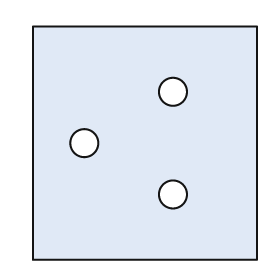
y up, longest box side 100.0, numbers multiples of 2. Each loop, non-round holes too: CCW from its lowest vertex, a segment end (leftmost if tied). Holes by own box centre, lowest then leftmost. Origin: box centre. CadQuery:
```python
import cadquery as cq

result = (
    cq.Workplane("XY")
    .moveTo(-48.0, -50.0)
    .lineTo(48.0, -50.0)
    .lineTo(48.0, 50.0)
    .lineTo(-48.0, 50.0)
    .close()
    .moveTo(12.0, -22.0)
    .circle(6.0)
    .moveTo(-26.0, 0.0)
    .circle(6.0)
    .moveTo(12.0, 22.0)
    .circle(6.0)
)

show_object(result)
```